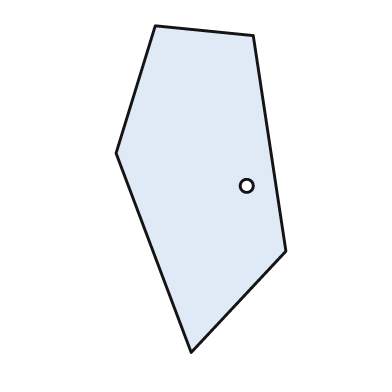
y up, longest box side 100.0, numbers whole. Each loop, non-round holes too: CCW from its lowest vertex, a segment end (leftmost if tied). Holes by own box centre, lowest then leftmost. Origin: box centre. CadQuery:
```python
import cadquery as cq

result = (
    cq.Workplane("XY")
    .moveTo(-3.0, -50.0)
    .lineTo(26.0, -19.0)
    .lineTo(16.0, 47.0)
    .lineTo(-14.0, 50.0)
    .lineTo(-26.0, 11.0)
    .close()
    .moveTo(14.0, 1.0)
    .circle(2.0)
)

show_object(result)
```